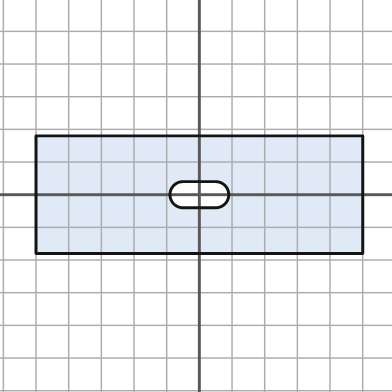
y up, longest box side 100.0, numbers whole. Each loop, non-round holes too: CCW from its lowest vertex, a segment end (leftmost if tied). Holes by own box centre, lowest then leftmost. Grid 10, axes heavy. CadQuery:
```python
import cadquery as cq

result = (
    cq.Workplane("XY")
    .moveTo(-50.0, -18.0)
    .lineTo(50.0, -18.0)
    .lineTo(50.0, 18.0)
    .lineTo(-50.0, 18.0)
    .close()
    .moveTo(-5.0, -4.0)
    .lineTo(5.0, -4.0)
    .threePointArc((9.0, 0.0), (5.0, 4.0))
    .lineTo(-5.0, 4.0)
    .threePointArc((-9.0, 0.0), (-5.0, -4.0))
    .close()
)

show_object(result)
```